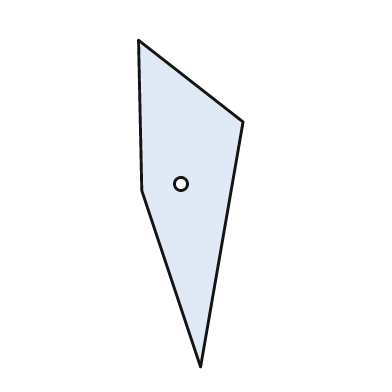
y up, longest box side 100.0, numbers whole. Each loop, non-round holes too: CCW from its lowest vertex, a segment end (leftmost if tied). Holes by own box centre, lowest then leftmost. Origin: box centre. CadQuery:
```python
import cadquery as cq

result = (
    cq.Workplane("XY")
    .moveTo(3.0, -50.0)
    .lineTo(16.0, 25.0)
    .lineTo(-16.0, 50.0)
    .lineTo(-15.0, 4.0)
    .close()
    .moveTo(-3.0, 6.0)
    .circle(2.0)
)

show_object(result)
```